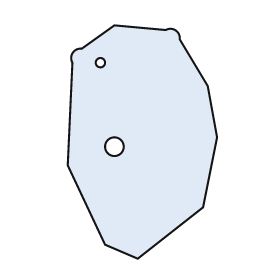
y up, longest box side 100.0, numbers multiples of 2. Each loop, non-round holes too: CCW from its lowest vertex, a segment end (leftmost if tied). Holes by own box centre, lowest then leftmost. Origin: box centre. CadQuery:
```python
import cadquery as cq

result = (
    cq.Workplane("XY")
    .moveTo(-2.0, -50.0)
    .lineTo(26.0, -28.0)
    .lineTo(32.0, 2.0)
    .lineTo(28.0, 24.0)
    .lineTo(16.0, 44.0)
    .threePointArc((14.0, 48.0), (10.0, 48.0))
    .lineTo(-12.0, 50.0)
    .lineTo(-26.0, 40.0)
    .threePointArc((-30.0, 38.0), (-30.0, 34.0))
    .lineTo(-32.0, -10.0)
    .lineTo(-16.0, -44.0)
    .close()
    .moveTo(-12.0, -2.0)
    .circle(4.0)
    .moveTo(-18.0, 34.0)
    .circle(2.0)
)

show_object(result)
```